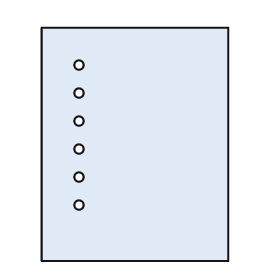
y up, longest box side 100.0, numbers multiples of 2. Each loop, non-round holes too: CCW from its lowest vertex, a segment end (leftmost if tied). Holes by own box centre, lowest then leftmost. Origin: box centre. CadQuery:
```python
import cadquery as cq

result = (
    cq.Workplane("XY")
    .moveTo(-40.0, -50.0)
    .lineTo(40.0, -50.0)
    .lineTo(40.0, 50.0)
    .lineTo(-40.0, 50.0)
    .close()
    .moveTo(-24.0, -26.0)
    .circle(2.0)
    .moveTo(-24.0, -14.0)
    .circle(2.0)
    .moveTo(-24.0, -2.0)
    .circle(2.0)
    .moveTo(-24.0, 10.0)
    .circle(2.0)
    .moveTo(-24.0, 22.0)
    .circle(2.0)
    .moveTo(-24.0, 34.0)
    .circle(2.0)
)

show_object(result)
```